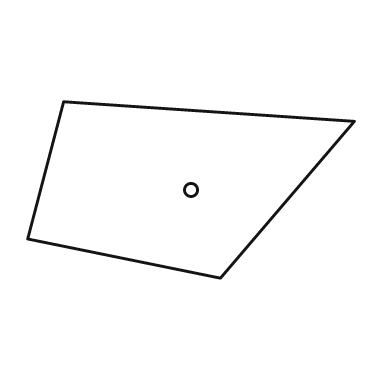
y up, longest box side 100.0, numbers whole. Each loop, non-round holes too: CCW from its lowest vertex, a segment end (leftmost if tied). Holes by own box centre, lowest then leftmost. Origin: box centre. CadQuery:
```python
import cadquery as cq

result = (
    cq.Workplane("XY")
    .moveTo(9.0, -27.0)
    .lineTo(50.0, 21.0)
    .lineTo(-39.0, 27.0)
    .lineTo(-50.0, -15.0)
    .close()
    .moveTo(0.0, 0.0)
    .circle(2.0)
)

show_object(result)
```